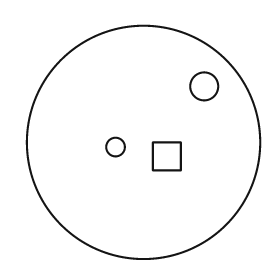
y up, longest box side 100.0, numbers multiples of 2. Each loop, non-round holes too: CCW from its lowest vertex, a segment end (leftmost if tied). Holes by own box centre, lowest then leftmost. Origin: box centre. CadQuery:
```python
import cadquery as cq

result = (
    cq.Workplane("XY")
    .moveTo(0.0, 0.0)
    .circle(50.0)
    .moveTo(4.0, -12.0)
    .lineTo(16.0, -12.0)
    .lineTo(16.0, 0.0)
    .lineTo(4.0, 0.0)
    .close()
    .moveTo(-12.0, -2.0)
    .circle(4.0)
    .moveTo(26.0, 24.0)
    .circle(6.0)
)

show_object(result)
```